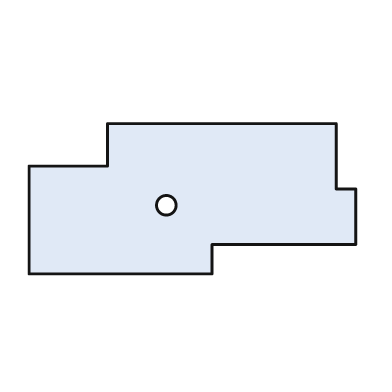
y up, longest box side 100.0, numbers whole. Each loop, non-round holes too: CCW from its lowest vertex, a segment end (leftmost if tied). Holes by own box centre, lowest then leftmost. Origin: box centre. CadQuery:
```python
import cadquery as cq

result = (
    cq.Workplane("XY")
    .moveTo(-50.0, -23.0)
    .lineTo(6.0, -23.0)
    .lineTo(6.0, -14.0)
    .lineTo(50.0, -14.0)
    .lineTo(50.0, 3.0)
    .lineTo(44.0, 3.0)
    .lineTo(44.0, 23.0)
    .lineTo(-26.0, 23.0)
    .lineTo(-26.0, 10.0)
    .lineTo(-50.0, 10.0)
    .close()
    .moveTo(-8.0, -2.0)
    .circle(3.0)
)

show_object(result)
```